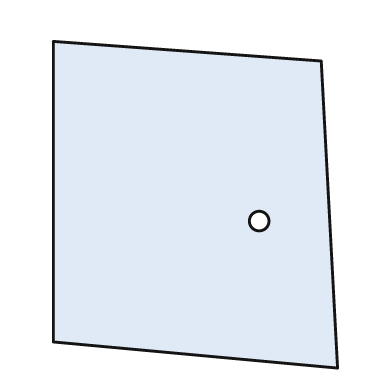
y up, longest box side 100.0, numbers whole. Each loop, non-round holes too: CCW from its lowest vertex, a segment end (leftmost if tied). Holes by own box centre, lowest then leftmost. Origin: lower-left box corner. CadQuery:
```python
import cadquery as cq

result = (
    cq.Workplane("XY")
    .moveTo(87.0, 0.0)
    .lineTo(82.0, 94.0)
    .lineTo(0.0, 100.0)
    .lineTo(0.0, 8.0)
    .close()
    .moveTo(63.0, 45.0)
    .circle(3.0)
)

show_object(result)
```